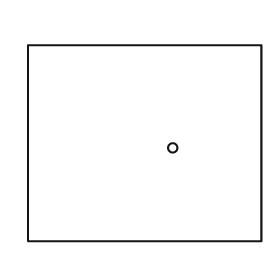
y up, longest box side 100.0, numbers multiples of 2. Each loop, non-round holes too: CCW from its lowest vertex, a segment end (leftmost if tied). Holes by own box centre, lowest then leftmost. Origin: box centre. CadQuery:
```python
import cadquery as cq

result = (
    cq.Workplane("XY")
    .moveTo(-50.0, -42.0)
    .lineTo(50.0, -42.0)
    .lineTo(50.0, 42.0)
    .lineTo(-50.0, 42.0)
    .close()
    .moveTo(12.0, -2.0)
    .circle(2.0)
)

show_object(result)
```